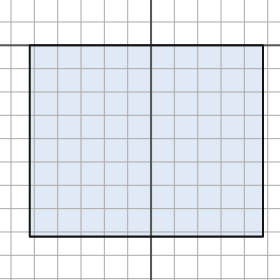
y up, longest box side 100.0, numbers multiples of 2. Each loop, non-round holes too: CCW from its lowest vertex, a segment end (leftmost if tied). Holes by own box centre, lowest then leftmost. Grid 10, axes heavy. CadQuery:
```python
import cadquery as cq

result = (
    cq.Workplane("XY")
    .moveTo(-52.0, -82.0)
    .lineTo(48.0, -82.0)
    .lineTo(48.0, 0.0)
    .lineTo(-52.0, 0.0)
    .close()
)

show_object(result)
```